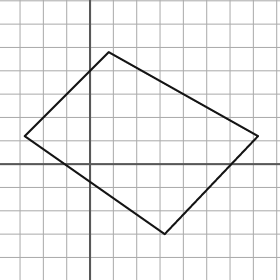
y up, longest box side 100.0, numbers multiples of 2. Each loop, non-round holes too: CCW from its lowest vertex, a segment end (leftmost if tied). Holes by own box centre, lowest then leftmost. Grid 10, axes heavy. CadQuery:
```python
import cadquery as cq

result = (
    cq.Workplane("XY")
    .moveTo(32.0, -30.0)
    .lineTo(72.0, 12.0)
    .lineTo(8.0, 48.0)
    .lineTo(-28.0, 12.0)
    .close()
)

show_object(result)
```